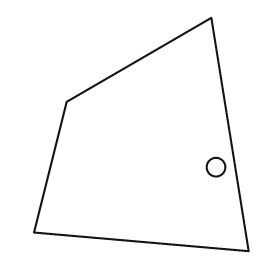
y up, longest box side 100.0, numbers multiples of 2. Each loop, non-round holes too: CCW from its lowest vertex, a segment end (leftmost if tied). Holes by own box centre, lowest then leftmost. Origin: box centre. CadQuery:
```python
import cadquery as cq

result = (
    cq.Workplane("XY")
    .moveTo(46.0, -50.0)
    .lineTo(30.0, 50.0)
    .lineTo(-32.0, 14.0)
    .lineTo(-46.0, -42.0)
    .close()
    .moveTo(32.0, -14.0)
    .circle(4.0)
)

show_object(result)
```